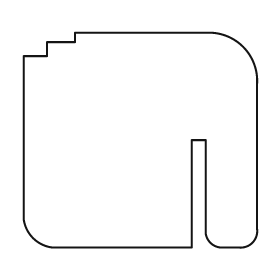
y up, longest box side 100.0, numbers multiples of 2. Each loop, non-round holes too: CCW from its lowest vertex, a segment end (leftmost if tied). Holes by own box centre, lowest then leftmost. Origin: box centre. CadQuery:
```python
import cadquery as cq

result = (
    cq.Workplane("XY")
    .moveTo(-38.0, -46.0)
    .lineTo(22.0, -46.0)
    .lineTo(22.0, 0.0)
    .lineTo(28.0, 0.0)
    .lineTo(28.0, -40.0)
    .threePointArc((30.0, -44.0), (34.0, -46.0))
    .lineTo(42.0, -46.0)
    .threePointArc((48.0, -44.0), (50.0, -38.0))
    .lineTo(50.0, 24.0)
    .threePointArc((44.0, 40.0), (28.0, 46.0))
    .lineTo(-28.0, 46.0)
    .lineTo(-28.0, 42.0)
    .lineTo(-40.0, 42.0)
    .lineTo(-40.0, 36.0)
    .lineTo(-50.0, 36.0)
    .lineTo(-50.0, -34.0)
    .threePointArc((-46.0, -42.0), (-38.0, -46.0))
    .close()
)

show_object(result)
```